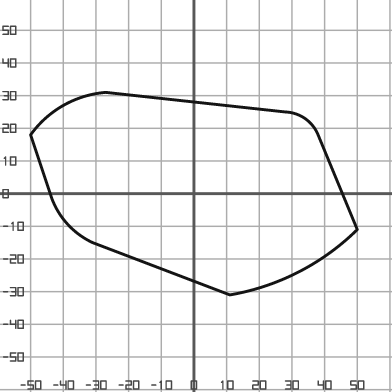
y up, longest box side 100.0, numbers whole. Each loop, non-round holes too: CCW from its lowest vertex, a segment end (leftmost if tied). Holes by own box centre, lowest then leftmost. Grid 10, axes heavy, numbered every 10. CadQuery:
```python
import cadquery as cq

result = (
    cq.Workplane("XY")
    .moveTo(11.0, -31.0)
    .threePointArc((32.0, -24.0), (50.0, -11.0))
    .lineTo(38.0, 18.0)
    .threePointArc((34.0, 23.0), (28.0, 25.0))
    .lineTo(-27.0, 31.0)
    .threePointArc((-40.0, 27.0), (-50.0, 18.0))
    .lineTo(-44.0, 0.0)
    .threePointArc((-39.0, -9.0), (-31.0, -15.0))
    .close()
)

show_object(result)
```